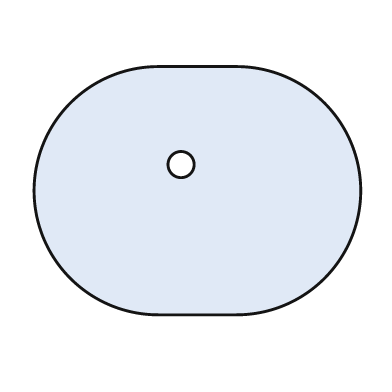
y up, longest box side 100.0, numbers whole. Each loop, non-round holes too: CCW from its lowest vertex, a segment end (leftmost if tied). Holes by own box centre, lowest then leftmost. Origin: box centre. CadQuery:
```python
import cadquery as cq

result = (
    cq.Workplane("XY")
    .moveTo(-12.0, -38.0)
    .lineTo(12.0, -38.0)
    .threePointArc((50.0, 0.0), (12.0, 38.0))
    .lineTo(-12.0, 38.0)
    .threePointArc((-50.0, 0.0), (-12.0, -38.0))
    .close()
    .moveTo(-5.0, 8.0)
    .circle(4.0)
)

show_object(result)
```